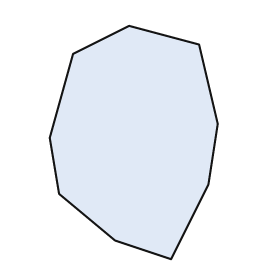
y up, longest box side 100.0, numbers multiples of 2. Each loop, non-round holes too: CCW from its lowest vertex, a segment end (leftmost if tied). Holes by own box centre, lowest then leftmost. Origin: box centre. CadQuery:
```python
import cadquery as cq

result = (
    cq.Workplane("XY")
    .moveTo(16.0, -50.0)
    .lineTo(32.0, -18.0)
    .lineTo(36.0, 8.0)
    .lineTo(28.0, 42.0)
    .lineTo(-2.0, 50.0)
    .lineTo(-26.0, 38.0)
    .lineTo(-36.0, 2.0)
    .lineTo(-32.0, -22.0)
    .lineTo(-8.0, -42.0)
    .close()
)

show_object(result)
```